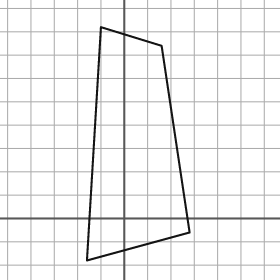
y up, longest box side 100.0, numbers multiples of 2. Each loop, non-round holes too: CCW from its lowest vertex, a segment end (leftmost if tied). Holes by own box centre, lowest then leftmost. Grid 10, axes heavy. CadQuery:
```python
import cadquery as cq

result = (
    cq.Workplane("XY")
    .moveTo(-16.0, -18.0)
    .lineTo(28.0, -6.0)
    .lineTo(16.0, 74.0)
    .lineTo(-10.0, 82.0)
    .close()
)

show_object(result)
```